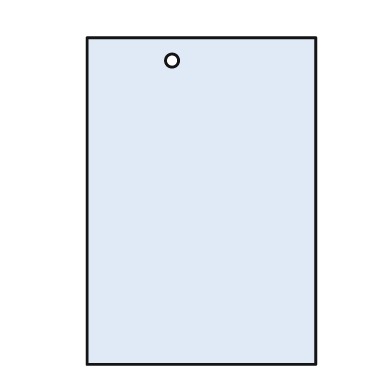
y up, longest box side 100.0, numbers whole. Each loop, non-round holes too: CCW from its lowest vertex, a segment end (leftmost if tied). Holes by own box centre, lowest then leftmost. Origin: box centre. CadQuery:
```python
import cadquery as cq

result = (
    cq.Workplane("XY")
    .moveTo(-35.0, -50.0)
    .lineTo(35.0, -50.0)
    .lineTo(35.0, 50.0)
    .lineTo(-35.0, 50.0)
    .close()
    .moveTo(-9.0, 43.0)
    .circle(2.0)
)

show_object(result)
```